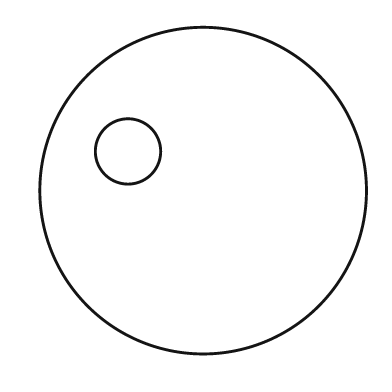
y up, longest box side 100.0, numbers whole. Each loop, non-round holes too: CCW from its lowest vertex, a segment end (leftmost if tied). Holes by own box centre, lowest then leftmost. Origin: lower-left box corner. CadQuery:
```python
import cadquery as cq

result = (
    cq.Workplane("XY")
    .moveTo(50.0, 50.0)
    .circle(50.0)
    .moveTo(27.0, 62.0)
    .circle(10.0)
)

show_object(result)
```